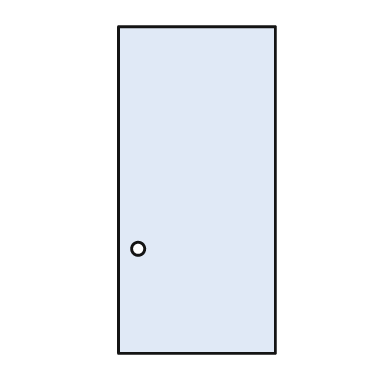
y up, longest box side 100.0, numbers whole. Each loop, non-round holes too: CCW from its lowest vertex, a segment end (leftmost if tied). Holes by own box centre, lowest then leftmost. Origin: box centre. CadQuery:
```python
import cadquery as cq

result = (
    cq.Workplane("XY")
    .moveTo(-24.0, -50.0)
    .lineTo(24.0, -50.0)
    .lineTo(24.0, 50.0)
    .lineTo(-24.0, 50.0)
    .close()
    .moveTo(-18.0, -18.0)
    .circle(2.0)
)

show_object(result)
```